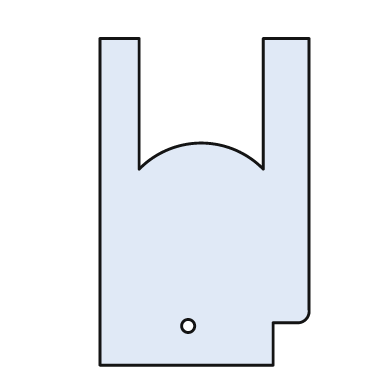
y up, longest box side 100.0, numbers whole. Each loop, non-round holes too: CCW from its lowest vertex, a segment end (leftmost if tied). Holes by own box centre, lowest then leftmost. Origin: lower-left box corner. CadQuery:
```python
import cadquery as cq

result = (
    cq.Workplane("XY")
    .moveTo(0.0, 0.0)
    .lineTo(53.0, 0.0)
    .lineTo(53.0, 13.0)
    .lineTo(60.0, 13.0)
    .threePointArc((63.0, 14.0), (64.0, 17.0))
    .lineTo(64.0, 100.0)
    .lineTo(50.0, 100.0)
    .lineTo(50.0, 60.0)
    .threePointArc((31.0, 68.0), (12.0, 60.0))
    .lineTo(12.0, 100.0)
    .lineTo(0.0, 100.0)
    .close()
    .moveTo(27.0, 12.0)
    .circle(2.0)
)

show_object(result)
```